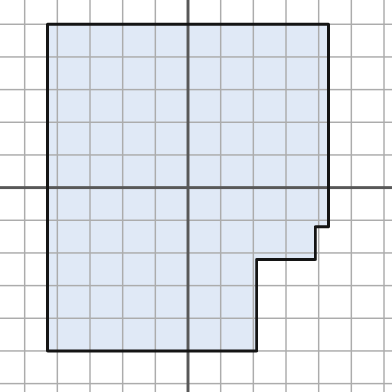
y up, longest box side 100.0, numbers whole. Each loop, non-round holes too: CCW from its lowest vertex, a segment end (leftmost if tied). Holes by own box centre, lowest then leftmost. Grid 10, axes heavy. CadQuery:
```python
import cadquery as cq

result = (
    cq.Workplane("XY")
    .moveTo(-43.0, -50.0)
    .lineTo(21.0, -50.0)
    .lineTo(21.0, -22.0)
    .lineTo(39.0, -22.0)
    .lineTo(39.0, -12.0)
    .lineTo(43.0, -12.0)
    .lineTo(43.0, 50.0)
    .lineTo(-43.0, 50.0)
    .close()
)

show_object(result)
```